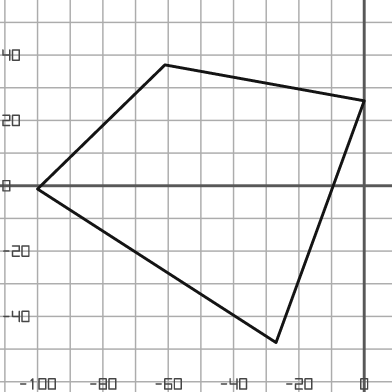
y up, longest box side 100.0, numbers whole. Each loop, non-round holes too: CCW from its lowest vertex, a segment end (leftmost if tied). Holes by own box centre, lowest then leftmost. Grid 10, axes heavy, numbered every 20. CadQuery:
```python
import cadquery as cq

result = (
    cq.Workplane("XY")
    .moveTo(-27.0, -48.0)
    .lineTo(0.0, 26.0)
    .lineTo(-61.0, 37.0)
    .lineTo(-100.0, -1.0)
    .close()
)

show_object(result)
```